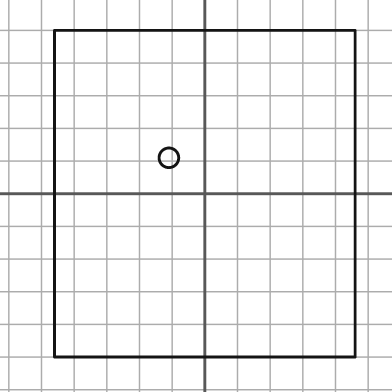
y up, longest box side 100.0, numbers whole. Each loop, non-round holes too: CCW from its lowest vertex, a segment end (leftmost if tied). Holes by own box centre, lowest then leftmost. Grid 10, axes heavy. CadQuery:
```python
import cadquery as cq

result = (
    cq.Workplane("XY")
    .moveTo(-46.0, -50.0)
    .lineTo(46.0, -50.0)
    .lineTo(46.0, 50.0)
    .lineTo(-46.0, 50.0)
    .close()
    .moveTo(-11.0, 11.0)
    .circle(3.0)
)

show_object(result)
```